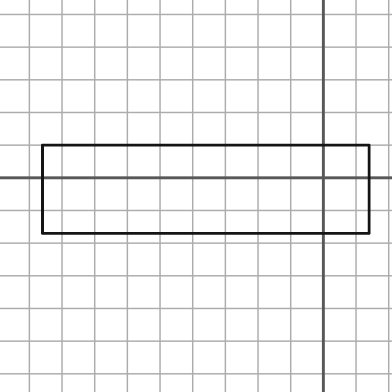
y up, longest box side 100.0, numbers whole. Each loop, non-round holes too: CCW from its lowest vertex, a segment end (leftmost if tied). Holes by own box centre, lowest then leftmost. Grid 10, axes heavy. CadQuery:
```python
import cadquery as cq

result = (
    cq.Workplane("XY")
    .moveTo(-86.0, -17.0)
    .lineTo(14.0, -17.0)
    .lineTo(14.0, 10.0)
    .lineTo(-86.0, 10.0)
    .close()
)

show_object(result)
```